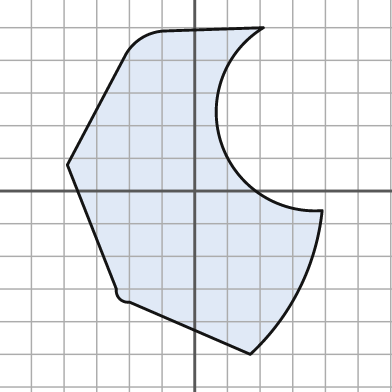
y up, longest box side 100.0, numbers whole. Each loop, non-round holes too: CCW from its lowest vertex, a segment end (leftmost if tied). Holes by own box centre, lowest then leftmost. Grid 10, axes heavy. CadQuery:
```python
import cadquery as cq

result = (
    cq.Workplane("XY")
    .moveTo(17.0, -50.0)
    .threePointArc((32.0, -30.0), (39.0, -6.0))
    .threePointArc((8.0, 15.0), (21.0, 50.0))
    .lineTo(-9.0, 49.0)
    .threePointArc((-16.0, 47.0), (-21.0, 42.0))
    .lineTo(-39.0, 8.0)
    .lineTo(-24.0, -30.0)
    .threePointArc((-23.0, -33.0), (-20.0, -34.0))
    .close()
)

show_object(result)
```